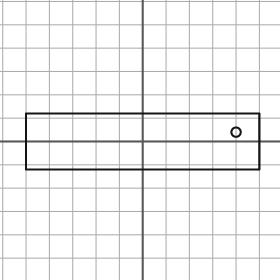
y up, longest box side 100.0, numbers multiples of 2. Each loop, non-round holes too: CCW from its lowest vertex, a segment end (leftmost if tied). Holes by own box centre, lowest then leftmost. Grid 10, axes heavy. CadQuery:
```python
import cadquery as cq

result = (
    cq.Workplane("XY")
    .moveTo(-50.0, -12.0)
    .lineTo(50.0, -12.0)
    .lineTo(50.0, 12.0)
    .lineTo(-50.0, 12.0)
    .close()
    .moveTo(40.0, 4.0)
    .circle(2.0)
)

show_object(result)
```